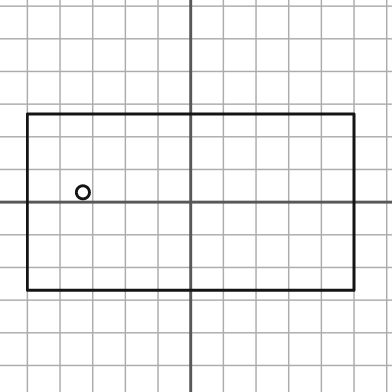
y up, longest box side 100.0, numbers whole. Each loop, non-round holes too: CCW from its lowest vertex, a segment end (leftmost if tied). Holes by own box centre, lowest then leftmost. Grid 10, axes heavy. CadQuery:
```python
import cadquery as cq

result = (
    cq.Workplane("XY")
    .moveTo(-50.0, -27.0)
    .lineTo(50.0, -27.0)
    .lineTo(50.0, 27.0)
    .lineTo(-50.0, 27.0)
    .close()
    .moveTo(-33.0, 3.0)
    .circle(2.0)
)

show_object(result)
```